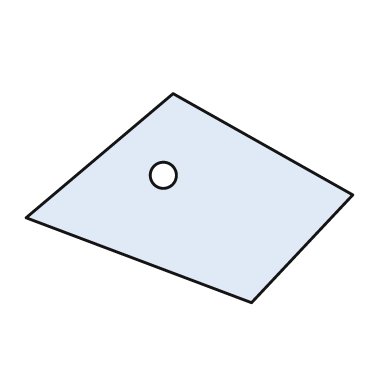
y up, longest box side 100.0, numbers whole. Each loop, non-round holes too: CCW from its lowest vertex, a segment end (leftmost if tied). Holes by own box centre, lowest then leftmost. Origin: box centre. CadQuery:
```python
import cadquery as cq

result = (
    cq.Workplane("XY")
    .moveTo(19.0, -32.0)
    .lineTo(50.0, 1.0)
    .lineTo(-5.0, 32.0)
    .lineTo(-50.0, -6.0)
    .close()
    .moveTo(-8.0, 7.0)
    .circle(4.0)
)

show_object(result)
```